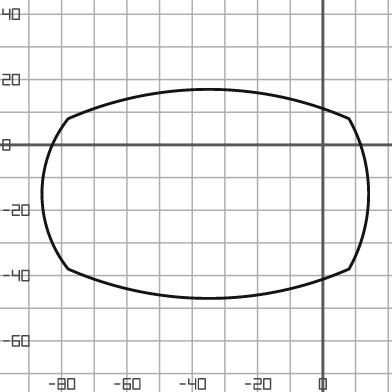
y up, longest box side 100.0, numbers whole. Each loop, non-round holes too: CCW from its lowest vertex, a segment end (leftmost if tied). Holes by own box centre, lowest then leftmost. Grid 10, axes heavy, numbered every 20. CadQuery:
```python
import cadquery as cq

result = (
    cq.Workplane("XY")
    .moveTo(-78.0, -38.0)
    .threePointArc((-35.0, -47.0), (8.0, -38.0))
    .threePointArc((14.0, -15.0), (8.0, 8.0))
    .threePointArc((-35.0, 17.0), (-78.0, 8.0))
    .threePointArc((-86.0, -15.0), (-78.0, -38.0))
    .close()
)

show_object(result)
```